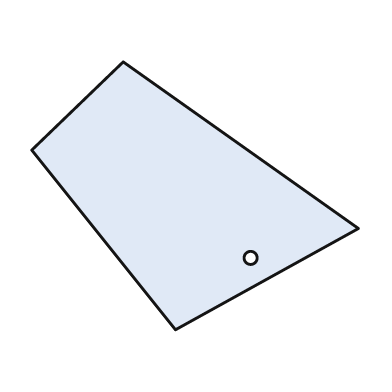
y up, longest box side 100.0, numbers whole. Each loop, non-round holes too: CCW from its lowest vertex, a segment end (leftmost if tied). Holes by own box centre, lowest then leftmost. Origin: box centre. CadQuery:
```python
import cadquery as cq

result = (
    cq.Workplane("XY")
    .moveTo(-6.0, -41.0)
    .lineTo(50.0, -10.0)
    .lineTo(-22.0, 41.0)
    .lineTo(-50.0, 14.0)
    .close()
    .moveTo(17.0, -19.0)
    .circle(2.0)
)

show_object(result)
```